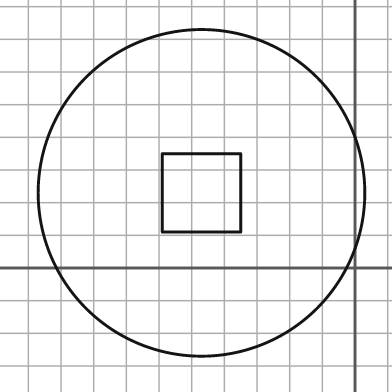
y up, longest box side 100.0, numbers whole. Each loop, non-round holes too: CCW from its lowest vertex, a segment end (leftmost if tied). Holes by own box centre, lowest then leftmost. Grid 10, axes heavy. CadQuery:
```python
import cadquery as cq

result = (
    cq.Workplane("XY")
    .moveTo(-47.0, 23.0)
    .circle(50.0)
    .moveTo(-59.0, 11.0)
    .lineTo(-35.0, 11.0)
    .lineTo(-35.0, 35.0)
    .lineTo(-59.0, 35.0)
    .close()
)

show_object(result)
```